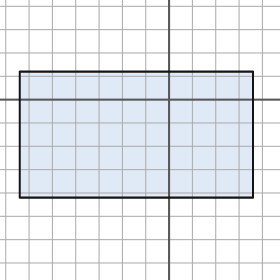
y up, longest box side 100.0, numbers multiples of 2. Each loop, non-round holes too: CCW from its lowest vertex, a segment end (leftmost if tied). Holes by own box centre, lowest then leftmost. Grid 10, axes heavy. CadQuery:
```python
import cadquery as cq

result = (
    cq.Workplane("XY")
    .moveTo(-64.0, -42.0)
    .lineTo(36.0, -42.0)
    .lineTo(36.0, 12.0)
    .lineTo(-64.0, 12.0)
    .close()
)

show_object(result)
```